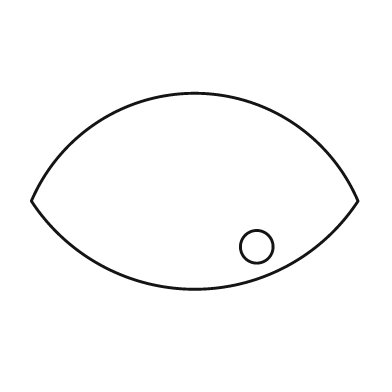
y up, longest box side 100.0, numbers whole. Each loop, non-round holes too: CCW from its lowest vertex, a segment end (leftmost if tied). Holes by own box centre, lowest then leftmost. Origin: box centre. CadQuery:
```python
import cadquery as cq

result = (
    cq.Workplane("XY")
    .moveTo(-50.0, -3.0)
    .threePointArc((0.0, -30.0), (50.0, -3.0))
    .threePointArc((0.0, 30.0), (-50.0, -3.0))
    .close()
    .moveTo(19.0, -17.0)
    .circle(5.0)
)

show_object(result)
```